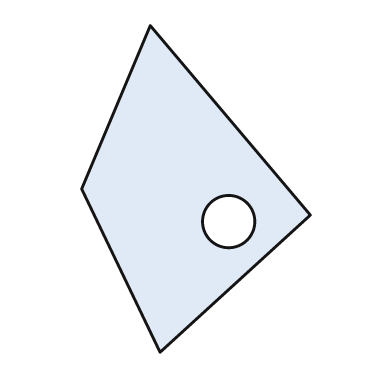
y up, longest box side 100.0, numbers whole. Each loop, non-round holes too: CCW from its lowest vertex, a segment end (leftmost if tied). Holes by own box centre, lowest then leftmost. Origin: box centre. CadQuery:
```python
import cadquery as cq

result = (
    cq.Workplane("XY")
    .moveTo(-11.0, -50.0)
    .lineTo(35.0, -8.0)
    .lineTo(-14.0, 50.0)
    .lineTo(-35.0, 0.0)
    .close()
    .moveTo(10.0, -10.0)
    .circle(8.0)
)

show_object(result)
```